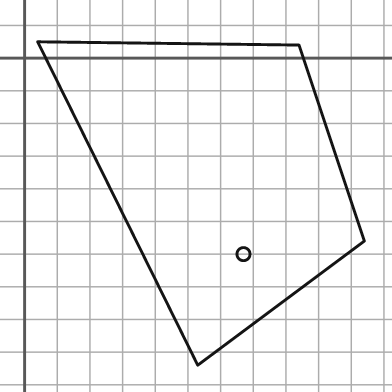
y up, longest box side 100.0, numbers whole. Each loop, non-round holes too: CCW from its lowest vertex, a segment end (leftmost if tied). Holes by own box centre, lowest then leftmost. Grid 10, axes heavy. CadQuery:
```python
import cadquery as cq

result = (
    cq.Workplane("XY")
    .moveTo(53.0, -94.0)
    .lineTo(104.0, -56.0)
    .lineTo(84.0, 4.0)
    .lineTo(4.0, 5.0)
    .close()
    .moveTo(67.0, -60.0)
    .circle(2.0)
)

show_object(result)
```